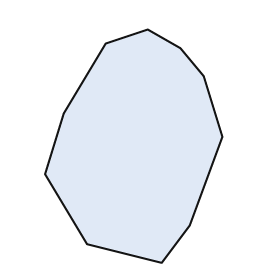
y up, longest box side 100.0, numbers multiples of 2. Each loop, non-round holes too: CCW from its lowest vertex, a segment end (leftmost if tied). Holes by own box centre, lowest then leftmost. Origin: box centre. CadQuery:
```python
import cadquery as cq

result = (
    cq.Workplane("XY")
    .moveTo(12.0, -50.0)
    .lineTo(24.0, -34.0)
    .lineTo(38.0, 4.0)
    .lineTo(30.0, 30.0)
    .lineTo(20.0, 42.0)
    .lineTo(6.0, 50.0)
    .lineTo(-12.0, 44.0)
    .lineTo(-30.0, 14.0)
    .lineTo(-38.0, -12.0)
    .lineTo(-20.0, -42.0)
    .close()
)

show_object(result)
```